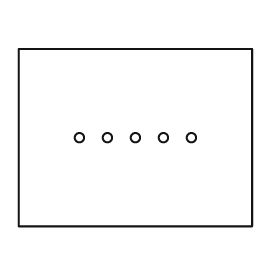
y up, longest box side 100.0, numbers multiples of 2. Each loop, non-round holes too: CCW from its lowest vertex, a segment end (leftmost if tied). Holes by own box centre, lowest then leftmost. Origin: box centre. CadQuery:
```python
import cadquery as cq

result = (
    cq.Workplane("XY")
    .moveTo(-50.0, -38.0)
    .lineTo(50.0, -38.0)
    .lineTo(50.0, 38.0)
    .lineTo(-50.0, 38.0)
    .close()
    .moveTo(-24.0, 0.0)
    .circle(2.0)
    .moveTo(-12.0, 0.0)
    .circle(2.0)
    .moveTo(0.0, 0.0)
    .circle(2.0)
    .moveTo(12.0, 0.0)
    .circle(2.0)
    .moveTo(24.0, 0.0)
    .circle(2.0)
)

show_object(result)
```